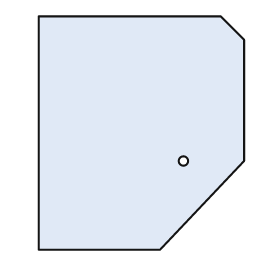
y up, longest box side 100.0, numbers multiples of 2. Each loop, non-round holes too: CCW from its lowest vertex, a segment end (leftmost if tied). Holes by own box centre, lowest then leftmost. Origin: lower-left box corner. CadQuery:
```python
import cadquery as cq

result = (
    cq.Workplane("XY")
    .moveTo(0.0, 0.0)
    .lineTo(52.0, 0.0)
    .lineTo(88.0, 38.0)
    .lineTo(88.0, 90.0)
    .lineTo(78.0, 100.0)
    .lineTo(0.0, 100.0)
    .close()
    .moveTo(62.0, 38.0)
    .circle(2.0)
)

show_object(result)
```